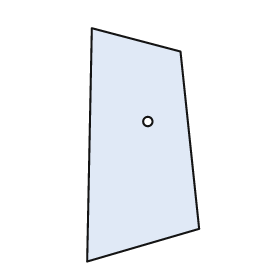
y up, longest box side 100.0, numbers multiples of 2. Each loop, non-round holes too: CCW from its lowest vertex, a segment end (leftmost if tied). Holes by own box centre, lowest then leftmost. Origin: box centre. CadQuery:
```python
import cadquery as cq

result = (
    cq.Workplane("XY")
    .moveTo(-24.0, -50.0)
    .lineTo(24.0, -36.0)
    .lineTo(16.0, 40.0)
    .lineTo(-22.0, 50.0)
    .close()
    .moveTo(2.0, 10.0)
    .circle(2.0)
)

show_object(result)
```